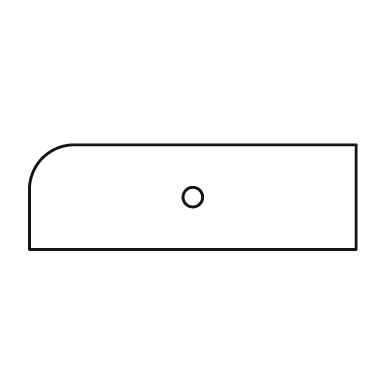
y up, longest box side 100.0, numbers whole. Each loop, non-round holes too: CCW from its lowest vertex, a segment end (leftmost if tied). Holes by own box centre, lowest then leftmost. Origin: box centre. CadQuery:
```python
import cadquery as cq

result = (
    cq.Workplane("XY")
    .moveTo(-50.0, -16.0)
    .lineTo(50.0, -16.0)
    .lineTo(50.0, 16.0)
    .lineTo(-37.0, 16.0)
    .threePointArc((-46.0, 12.0), (-50.0, 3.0))
    .close()
    .moveTo(0.0, 0.0)
    .circle(3.0)
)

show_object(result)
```